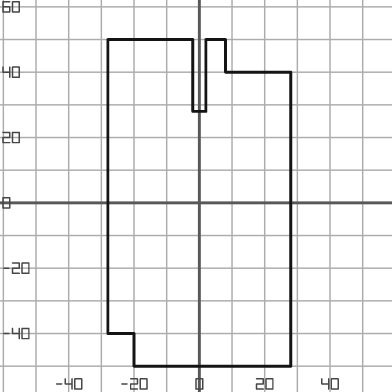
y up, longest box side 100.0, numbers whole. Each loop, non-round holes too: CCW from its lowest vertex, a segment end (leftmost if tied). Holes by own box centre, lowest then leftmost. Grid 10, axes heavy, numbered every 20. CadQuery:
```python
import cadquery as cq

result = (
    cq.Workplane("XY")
    .moveTo(-20.0, -50.0)
    .lineTo(28.0, -50.0)
    .lineTo(28.0, 40.0)
    .lineTo(8.0, 40.0)
    .lineTo(8.0, 50.0)
    .lineTo(2.0, 50.0)
    .lineTo(2.0, 28.0)
    .lineTo(-2.0, 28.0)
    .lineTo(-2.0, 50.0)
    .lineTo(-28.0, 50.0)
    .lineTo(-28.0, -40.0)
    .lineTo(-20.0, -40.0)
    .close()
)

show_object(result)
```